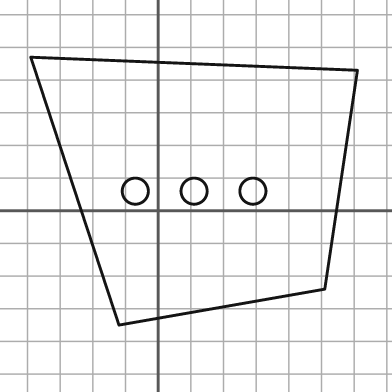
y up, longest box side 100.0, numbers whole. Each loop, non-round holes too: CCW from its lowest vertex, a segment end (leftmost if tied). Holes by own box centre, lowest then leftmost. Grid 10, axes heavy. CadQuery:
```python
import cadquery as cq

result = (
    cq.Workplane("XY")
    .moveTo(-12.0, -35.0)
    .lineTo(51.0, -24.0)
    .lineTo(61.0, 43.0)
    .lineTo(-39.0, 47.0)
    .close()
    .moveTo(-7.0, 6.0)
    .circle(4.0)
    .moveTo(11.0, 6.0)
    .circle(4.0)
    .moveTo(29.0, 6.0)
    .circle(4.0)
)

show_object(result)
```